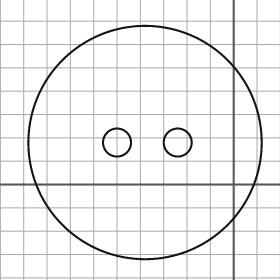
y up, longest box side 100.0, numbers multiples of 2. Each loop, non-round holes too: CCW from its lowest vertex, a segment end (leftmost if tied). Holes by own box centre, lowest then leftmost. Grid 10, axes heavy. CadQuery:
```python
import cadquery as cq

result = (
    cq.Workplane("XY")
    .moveTo(-38.0, 18.0)
    .circle(50.0)
    .moveTo(-50.0, 18.0)
    .circle(6.0)
    .moveTo(-24.0, 18.0)
    .circle(6.0)
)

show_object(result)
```